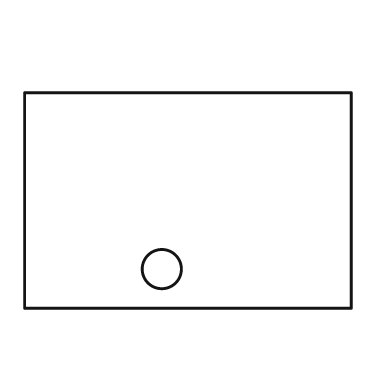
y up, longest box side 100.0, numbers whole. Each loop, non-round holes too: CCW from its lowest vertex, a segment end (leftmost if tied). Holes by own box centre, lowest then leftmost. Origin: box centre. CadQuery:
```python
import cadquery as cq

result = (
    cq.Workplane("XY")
    .moveTo(-50.0, -33.0)
    .lineTo(50.0, -33.0)
    .lineTo(50.0, 33.0)
    .lineTo(-50.0, 33.0)
    .close()
    .moveTo(-8.0, -21.0)
    .circle(6.0)
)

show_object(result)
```